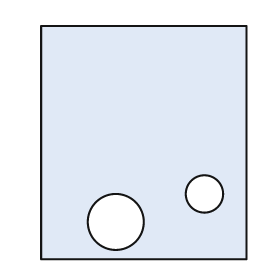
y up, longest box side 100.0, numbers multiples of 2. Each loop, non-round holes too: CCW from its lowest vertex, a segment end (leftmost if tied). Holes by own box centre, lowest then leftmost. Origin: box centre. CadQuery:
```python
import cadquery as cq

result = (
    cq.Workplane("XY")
    .moveTo(-44.0, -50.0)
    .lineTo(44.0, -50.0)
    .lineTo(44.0, 50.0)
    .lineTo(-44.0, 50.0)
    .close()
    .moveTo(-12.0, -34.0)
    .circle(12.0)
    .moveTo(26.0, -22.0)
    .circle(8.0)
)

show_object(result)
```